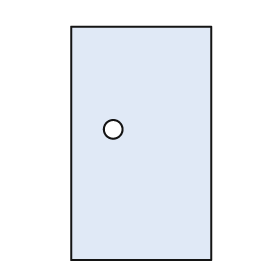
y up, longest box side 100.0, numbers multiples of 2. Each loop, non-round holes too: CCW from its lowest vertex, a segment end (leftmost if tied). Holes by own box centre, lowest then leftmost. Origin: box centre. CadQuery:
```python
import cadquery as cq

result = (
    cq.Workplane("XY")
    .moveTo(-30.0, -50.0)
    .lineTo(30.0, -50.0)
    .lineTo(30.0, 50.0)
    .lineTo(-30.0, 50.0)
    .close()
    .moveTo(-12.0, 6.0)
    .circle(4.0)
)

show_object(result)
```